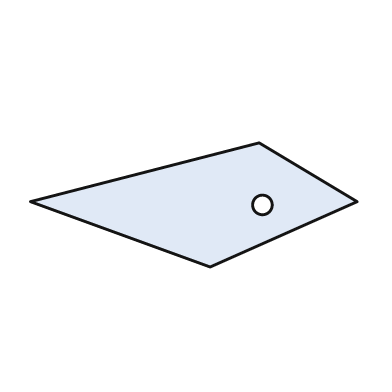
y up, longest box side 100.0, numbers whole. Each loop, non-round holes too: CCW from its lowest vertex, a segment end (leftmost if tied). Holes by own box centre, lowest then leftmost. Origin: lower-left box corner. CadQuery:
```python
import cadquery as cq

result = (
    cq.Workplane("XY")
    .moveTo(55.0, 0.0)
    .lineTo(100.0, 20.0)
    .lineTo(70.0, 38.0)
    .lineTo(0.0, 20.0)
    .close()
    .moveTo(71.0, 19.0)
    .circle(3.0)
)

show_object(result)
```